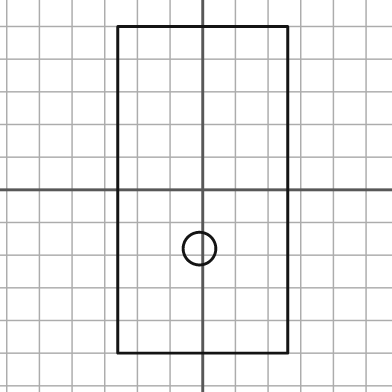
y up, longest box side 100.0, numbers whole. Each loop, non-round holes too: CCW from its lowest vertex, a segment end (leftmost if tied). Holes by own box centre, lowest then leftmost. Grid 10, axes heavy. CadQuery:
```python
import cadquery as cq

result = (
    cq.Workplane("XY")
    .moveTo(-26.0, -50.0)
    .lineTo(26.0, -50.0)
    .lineTo(26.0, 50.0)
    .lineTo(-26.0, 50.0)
    .close()
    .moveTo(-1.0, -18.0)
    .circle(5.0)
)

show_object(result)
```